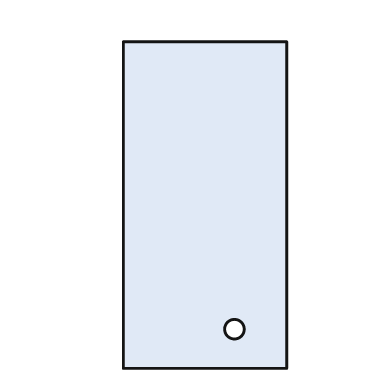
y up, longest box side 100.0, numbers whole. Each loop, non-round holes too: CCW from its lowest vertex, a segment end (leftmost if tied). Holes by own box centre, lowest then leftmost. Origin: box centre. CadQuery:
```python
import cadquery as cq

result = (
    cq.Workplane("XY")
    .moveTo(-25.0, -50.0)
    .lineTo(25.0, -50.0)
    .lineTo(25.0, 50.0)
    .lineTo(-25.0, 50.0)
    .close()
    .moveTo(9.0, -38.0)
    .circle(3.0)
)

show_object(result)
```